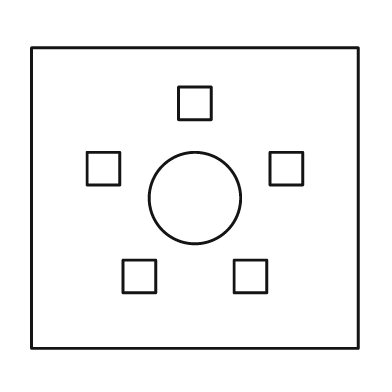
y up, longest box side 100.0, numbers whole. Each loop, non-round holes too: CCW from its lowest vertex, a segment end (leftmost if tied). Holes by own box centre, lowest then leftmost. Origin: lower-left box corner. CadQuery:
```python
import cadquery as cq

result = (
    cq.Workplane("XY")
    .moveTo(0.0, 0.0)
    .lineTo(100.0, 0.0)
    .lineTo(100.0, 92.0)
    .lineTo(0.0, 92.0)
    .close()
    .moveTo(28.0, 17.0)
    .lineTo(38.0, 17.0)
    .lineTo(38.0, 27.0)
    .lineTo(28.0, 27.0)
    .close()
    .moveTo(62.0, 17.0)
    .lineTo(72.0, 17.0)
    .lineTo(72.0, 27.0)
    .lineTo(62.0, 27.0)
    .close()
    .moveTo(50.0, 46.0)
    .circle(14.0)
    .moveTo(17.0, 50.0)
    .lineTo(27.0, 50.0)
    .lineTo(27.0, 60.0)
    .lineTo(17.0, 60.0)
    .close()
    .moveTo(73.0, 50.0)
    .lineTo(83.0, 50.0)
    .lineTo(83.0, 60.0)
    .lineTo(73.0, 60.0)
    .close()
    .moveTo(45.0, 70.0)
    .lineTo(55.0, 70.0)
    .lineTo(55.0, 80.0)
    .lineTo(45.0, 80.0)
    .close()
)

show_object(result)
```